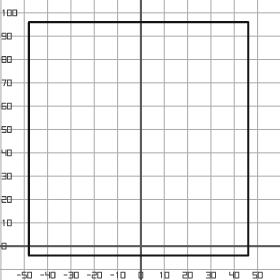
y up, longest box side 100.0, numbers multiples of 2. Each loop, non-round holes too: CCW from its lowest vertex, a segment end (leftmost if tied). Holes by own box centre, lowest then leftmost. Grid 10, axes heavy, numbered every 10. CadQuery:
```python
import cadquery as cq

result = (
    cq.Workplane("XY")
    .moveTo(-48.0, -4.0)
    .lineTo(46.0, -4.0)
    .lineTo(46.0, 96.0)
    .lineTo(-48.0, 96.0)
    .close()
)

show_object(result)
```